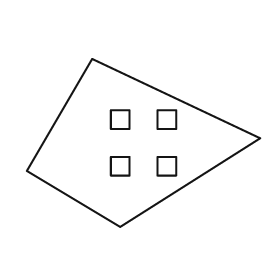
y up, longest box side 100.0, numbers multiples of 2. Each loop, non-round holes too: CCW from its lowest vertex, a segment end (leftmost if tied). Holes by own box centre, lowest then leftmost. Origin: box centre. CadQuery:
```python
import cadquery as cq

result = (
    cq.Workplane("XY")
    .moveTo(-10.0, -36.0)
    .lineTo(50.0, 2.0)
    .lineTo(-22.0, 36.0)
    .lineTo(-50.0, -12.0)
    .close()
    .moveTo(-14.0, -14.0)
    .lineTo(-6.0, -14.0)
    .lineTo(-6.0, -6.0)
    .lineTo(-14.0, -6.0)
    .close()
    .moveTo(6.0, -14.0)
    .lineTo(14.0, -14.0)
    .lineTo(14.0, -6.0)
    .lineTo(6.0, -6.0)
    .close()
    .moveTo(-14.0, 6.0)
    .lineTo(-6.0, 6.0)
    .lineTo(-6.0, 14.0)
    .lineTo(-14.0, 14.0)
    .close()
    .moveTo(6.0, 6.0)
    .lineTo(14.0, 6.0)
    .lineTo(14.0, 14.0)
    .lineTo(6.0, 14.0)
    .close()
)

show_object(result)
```